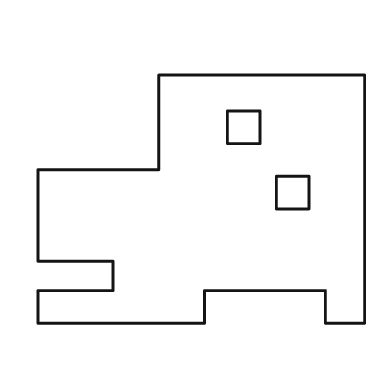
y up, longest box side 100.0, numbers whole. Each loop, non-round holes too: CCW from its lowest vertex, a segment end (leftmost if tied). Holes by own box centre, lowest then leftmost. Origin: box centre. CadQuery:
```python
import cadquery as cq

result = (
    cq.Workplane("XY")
    .moveTo(-50.0, -38.0)
    .lineTo(1.0, -38.0)
    .lineTo(1.0, -28.0)
    .lineTo(38.0, -28.0)
    .lineTo(38.0, -38.0)
    .lineTo(50.0, -38.0)
    .lineTo(50.0, 38.0)
    .lineTo(-13.0, 38.0)
    .lineTo(-13.0, 9.0)
    .lineTo(-50.0, 9.0)
    .lineTo(-50.0, -19.0)
    .lineTo(-27.0, -19.0)
    .lineTo(-27.0, -28.0)
    .lineTo(-50.0, -28.0)
    .close()
    .moveTo(23.0, -3.0)
    .lineTo(33.0, -3.0)
    .lineTo(33.0, 7.0)
    .lineTo(23.0, 7.0)
    .close()
    .moveTo(8.0, 17.0)
    .lineTo(18.0, 17.0)
    .lineTo(18.0, 27.0)
    .lineTo(8.0, 27.0)
    .close()
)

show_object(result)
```